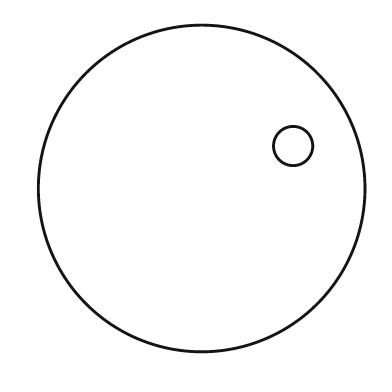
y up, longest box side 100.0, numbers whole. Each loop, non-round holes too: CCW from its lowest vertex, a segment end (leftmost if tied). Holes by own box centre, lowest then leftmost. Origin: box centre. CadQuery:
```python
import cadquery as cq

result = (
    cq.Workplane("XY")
    .moveTo(0.0, 0.0)
    .circle(50.0)
    .moveTo(28.0, 13.0)
    .circle(6.0)
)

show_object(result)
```